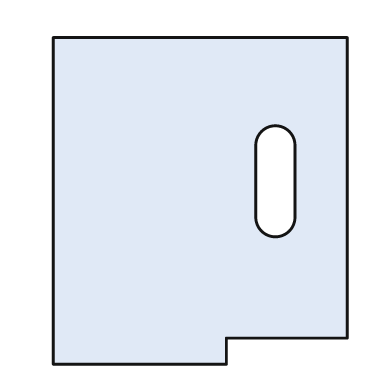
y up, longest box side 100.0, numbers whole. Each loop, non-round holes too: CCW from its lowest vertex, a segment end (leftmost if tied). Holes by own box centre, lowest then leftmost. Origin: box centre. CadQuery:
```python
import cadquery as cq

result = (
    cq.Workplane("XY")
    .moveTo(-45.0, -50.0)
    .lineTo(8.0, -50.0)
    .lineTo(8.0, -42.0)
    .lineTo(45.0, -42.0)
    .lineTo(45.0, 50.0)
    .lineTo(-45.0, 50.0)
    .close()
    .moveTo(17.0, -5.0)
    .threePointArc((23.0, -11.0), (29.0, -5.0))
    .lineTo(29.0, 17.0)
    .threePointArc((23.0, 23.0), (17.0, 17.0))
    .close()
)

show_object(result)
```